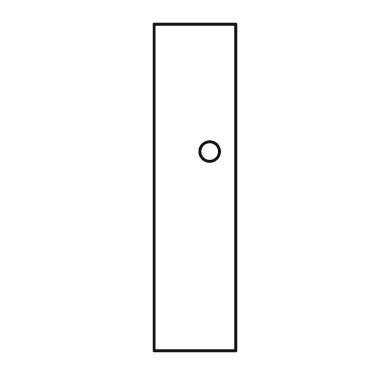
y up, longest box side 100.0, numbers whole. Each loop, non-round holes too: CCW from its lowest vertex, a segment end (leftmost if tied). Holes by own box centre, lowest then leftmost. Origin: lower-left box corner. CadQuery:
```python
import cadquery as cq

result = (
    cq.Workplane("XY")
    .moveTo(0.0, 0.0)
    .lineTo(25.0, 0.0)
    .lineTo(25.0, 100.0)
    .lineTo(0.0, 100.0)
    .close()
    .moveTo(17.0, 61.0)
    .circle(3.0)
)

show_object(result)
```